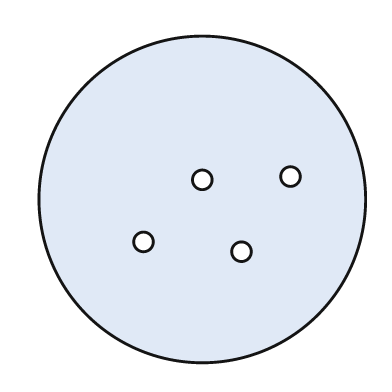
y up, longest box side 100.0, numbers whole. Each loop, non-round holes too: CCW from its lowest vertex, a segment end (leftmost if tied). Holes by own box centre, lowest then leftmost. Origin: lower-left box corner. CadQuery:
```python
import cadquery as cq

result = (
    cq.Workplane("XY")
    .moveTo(50.0, 50.0)
    .circle(50.0)
    .moveTo(62.0, 34.0)
    .circle(3.0)
    .moveTo(32.0, 37.0)
    .circle(3.0)
    .moveTo(50.0, 56.0)
    .circle(3.0)
    .moveTo(77.0, 57.0)
    .circle(3.0)
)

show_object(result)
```